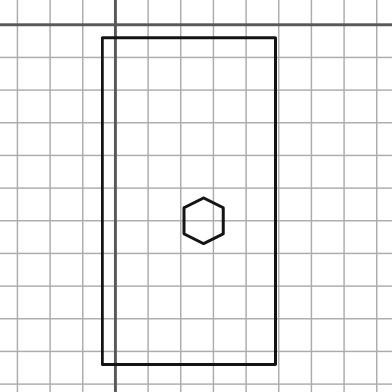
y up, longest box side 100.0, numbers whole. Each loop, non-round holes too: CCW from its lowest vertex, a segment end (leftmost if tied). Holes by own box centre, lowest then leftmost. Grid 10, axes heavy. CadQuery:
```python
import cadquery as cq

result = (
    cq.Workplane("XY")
    .moveTo(-4.0, -104.0)
    .lineTo(49.0, -104.0)
    .lineTo(49.0, -4.0)
    .lineTo(-4.0, -4.0)
    .close()
    .moveTo(27.0, -67.0)
    .lineTo(33.0, -64.0)
    .lineTo(33.0, -56.0)
    .lineTo(27.0, -53.0)
    .lineTo(21.0, -56.0)
    .lineTo(21.0, -64.0)
    .close()
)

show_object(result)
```